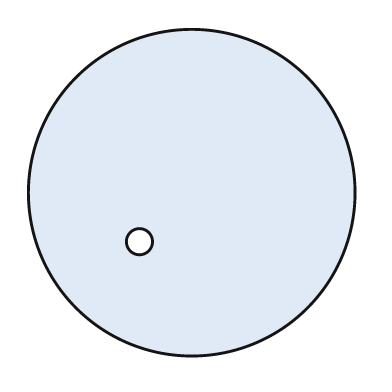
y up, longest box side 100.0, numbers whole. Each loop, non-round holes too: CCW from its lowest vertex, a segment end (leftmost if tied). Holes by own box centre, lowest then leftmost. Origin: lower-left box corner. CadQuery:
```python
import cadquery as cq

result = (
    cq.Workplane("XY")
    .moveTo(50.0, 50.0)
    .circle(50.0)
    .moveTo(34.0, 35.0)
    .circle(4.0)
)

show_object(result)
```